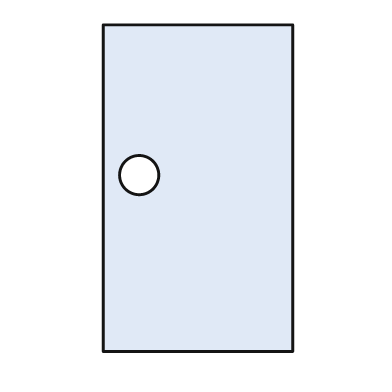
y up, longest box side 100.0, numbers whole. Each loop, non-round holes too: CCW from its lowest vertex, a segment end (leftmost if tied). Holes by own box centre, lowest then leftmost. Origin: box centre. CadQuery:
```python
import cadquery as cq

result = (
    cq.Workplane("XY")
    .moveTo(-29.0, -50.0)
    .lineTo(29.0, -50.0)
    .lineTo(29.0, 50.0)
    .lineTo(-29.0, 50.0)
    .close()
    .moveTo(-18.0, 4.0)
    .circle(6.0)
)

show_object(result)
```